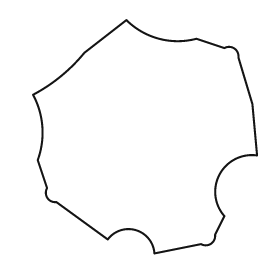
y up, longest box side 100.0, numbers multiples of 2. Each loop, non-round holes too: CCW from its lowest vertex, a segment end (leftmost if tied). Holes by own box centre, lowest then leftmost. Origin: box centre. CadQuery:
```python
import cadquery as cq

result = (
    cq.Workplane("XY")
    .moveTo(4.0, -50.0)
    .lineTo(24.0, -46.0)
    .threePointArc((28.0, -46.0), (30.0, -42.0))
    .lineTo(34.0, -34.0)
    .threePointArc((32.0, -16.0), (48.0, -8.0))
    .lineTo(46.0, 14.0)
    .lineTo(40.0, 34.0)
    .threePointArc((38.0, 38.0), (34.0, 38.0))
    .lineTo(22.0, 42.0)
    .threePointArc((6.0, 42.0), (-8.0, 50.0))
    .lineTo(-26.0, 36.0)
    .threePointArc((-36.0, 26.0), (-48.0, 18.0))
    .threePointArc((-44.0, 4.0), (-46.0, -10.0))
    .lineTo(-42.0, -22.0)
    .threePointArc((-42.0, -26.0), (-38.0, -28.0))
    .lineTo(-16.0, -44.0)
    .threePointArc((-4.0, -40.0), (4.0, -50.0))
    .close()
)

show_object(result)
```